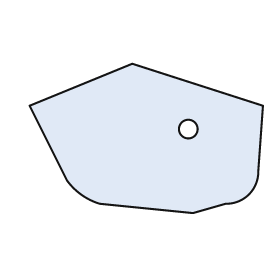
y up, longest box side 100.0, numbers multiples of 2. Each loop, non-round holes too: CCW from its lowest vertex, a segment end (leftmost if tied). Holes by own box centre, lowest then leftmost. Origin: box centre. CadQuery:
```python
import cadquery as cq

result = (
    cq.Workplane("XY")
    .moveTo(20.0, -32.0)
    .lineTo(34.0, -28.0)
    .threePointArc((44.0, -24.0), (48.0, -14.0))
    .lineTo(50.0, 14.0)
    .lineTo(-6.0, 32.0)
    .lineTo(-50.0, 14.0)
    .lineTo(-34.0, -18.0)
    .threePointArc((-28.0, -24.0), (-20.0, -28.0))
    .close()
    .moveTo(18.0, 4.0)
    .circle(4.0)
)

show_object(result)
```